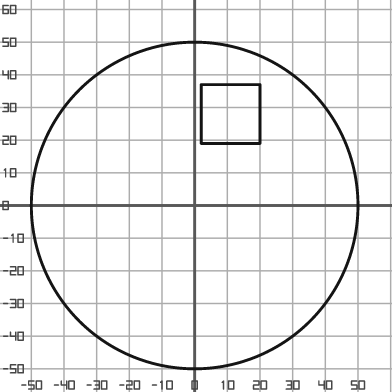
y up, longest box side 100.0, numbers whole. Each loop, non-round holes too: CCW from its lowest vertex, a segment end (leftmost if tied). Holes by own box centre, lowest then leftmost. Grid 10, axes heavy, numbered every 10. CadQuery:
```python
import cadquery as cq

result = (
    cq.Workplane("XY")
    .moveTo(0.0, 0.0)
    .circle(50.0)
    .moveTo(2.0, 19.0)
    .lineTo(20.0, 19.0)
    .lineTo(20.0, 37.0)
    .lineTo(2.0, 37.0)
    .close()
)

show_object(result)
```